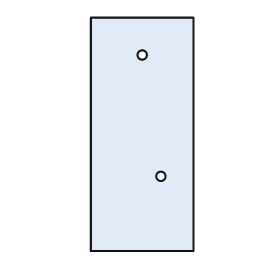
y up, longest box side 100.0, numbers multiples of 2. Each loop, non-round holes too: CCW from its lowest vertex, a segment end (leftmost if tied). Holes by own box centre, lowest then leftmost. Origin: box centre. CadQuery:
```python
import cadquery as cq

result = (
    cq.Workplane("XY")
    .moveTo(-22.0, -50.0)
    .lineTo(22.0, -50.0)
    .lineTo(22.0, 50.0)
    .lineTo(-22.0, 50.0)
    .close()
    .moveTo(8.0, -18.0)
    .circle(2.0)
    .moveTo(0.0, 34.0)
    .circle(2.0)
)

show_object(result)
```